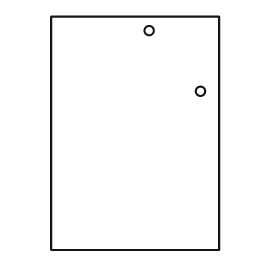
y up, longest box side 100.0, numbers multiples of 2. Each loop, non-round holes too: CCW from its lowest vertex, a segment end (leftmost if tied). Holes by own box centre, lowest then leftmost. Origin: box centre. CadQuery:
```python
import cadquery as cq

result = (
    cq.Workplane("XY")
    .moveTo(-36.0, -50.0)
    .lineTo(36.0, -50.0)
    .lineTo(36.0, 50.0)
    .lineTo(-36.0, 50.0)
    .close()
    .moveTo(28.0, 18.0)
    .circle(2.0)
    .moveTo(6.0, 44.0)
    .circle(2.0)
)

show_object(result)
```